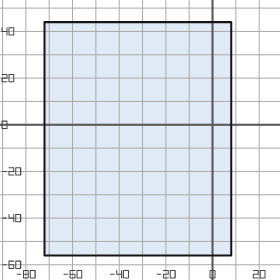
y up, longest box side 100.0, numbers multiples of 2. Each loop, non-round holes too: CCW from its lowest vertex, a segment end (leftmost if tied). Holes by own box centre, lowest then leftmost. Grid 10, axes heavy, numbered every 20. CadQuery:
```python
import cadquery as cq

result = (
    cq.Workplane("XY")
    .moveTo(-72.0, -56.0)
    .lineTo(8.0, -56.0)
    .lineTo(8.0, 44.0)
    .lineTo(-72.0, 44.0)
    .close()
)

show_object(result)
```